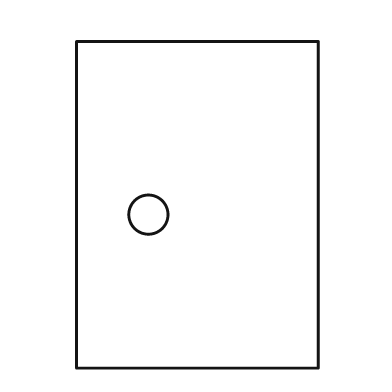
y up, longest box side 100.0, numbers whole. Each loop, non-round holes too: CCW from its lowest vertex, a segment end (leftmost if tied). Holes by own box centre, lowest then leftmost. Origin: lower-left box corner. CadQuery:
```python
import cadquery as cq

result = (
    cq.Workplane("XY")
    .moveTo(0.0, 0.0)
    .lineTo(74.0, 0.0)
    .lineTo(74.0, 100.0)
    .lineTo(0.0, 100.0)
    .close()
    .moveTo(22.0, 47.0)
    .circle(6.0)
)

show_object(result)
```